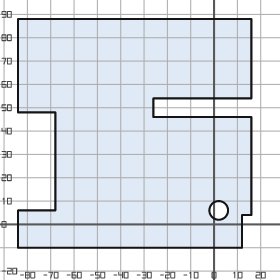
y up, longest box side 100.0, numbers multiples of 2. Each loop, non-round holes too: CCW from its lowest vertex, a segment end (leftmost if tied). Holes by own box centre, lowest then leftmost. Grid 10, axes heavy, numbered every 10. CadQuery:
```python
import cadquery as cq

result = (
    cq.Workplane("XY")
    .moveTo(-84.0, -10.0)
    .lineTo(12.0, -10.0)
    .lineTo(12.0, 4.0)
    .lineTo(16.0, 4.0)
    .lineTo(16.0, 46.0)
    .lineTo(-26.0, 46.0)
    .lineTo(-26.0, 54.0)
    .lineTo(16.0, 54.0)
    .lineTo(16.0, 88.0)
    .lineTo(-84.0, 88.0)
    .lineTo(-84.0, 48.0)
    .lineTo(-68.0, 48.0)
    .lineTo(-68.0, 6.0)
    .lineTo(-84.0, 6.0)
    .close()
    .moveTo(2.0, 6.0)
    .circle(4.0)
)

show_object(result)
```